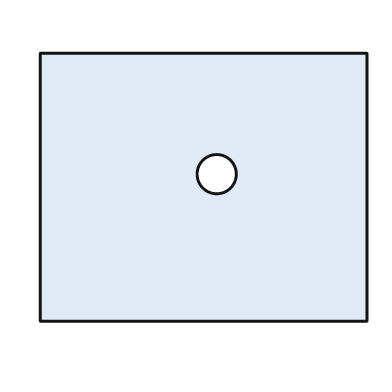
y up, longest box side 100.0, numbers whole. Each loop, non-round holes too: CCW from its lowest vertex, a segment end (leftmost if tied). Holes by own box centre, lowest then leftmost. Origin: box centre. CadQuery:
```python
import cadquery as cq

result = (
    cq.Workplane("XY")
    .moveTo(-50.0, -41.0)
    .lineTo(50.0, -41.0)
    .lineTo(50.0, 41.0)
    .lineTo(-50.0, 41.0)
    .close()
    .moveTo(4.0, 4.0)
    .circle(6.0)
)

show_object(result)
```